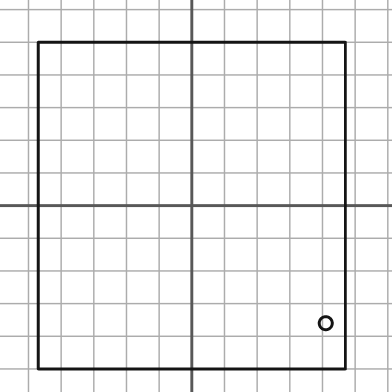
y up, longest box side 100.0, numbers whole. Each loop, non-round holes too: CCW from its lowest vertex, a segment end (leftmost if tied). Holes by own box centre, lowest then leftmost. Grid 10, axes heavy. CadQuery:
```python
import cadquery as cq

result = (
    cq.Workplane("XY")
    .moveTo(-47.0, -50.0)
    .lineTo(47.0, -50.0)
    .lineTo(47.0, 50.0)
    .lineTo(-47.0, 50.0)
    .close()
    .moveTo(41.0, -36.0)
    .circle(2.0)
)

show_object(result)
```